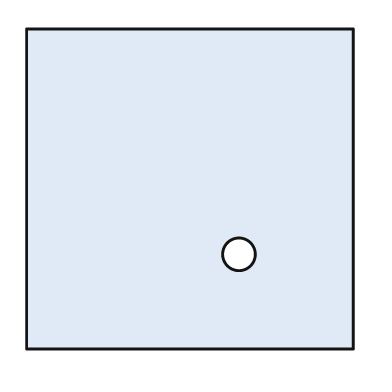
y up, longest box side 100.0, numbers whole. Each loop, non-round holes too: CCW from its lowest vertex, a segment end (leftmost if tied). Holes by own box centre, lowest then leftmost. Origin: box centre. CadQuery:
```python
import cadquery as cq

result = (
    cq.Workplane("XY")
    .moveTo(-50.0, -49.0)
    .lineTo(50.0, -49.0)
    .lineTo(50.0, 49.0)
    .lineTo(-50.0, 49.0)
    .close()
    .moveTo(15.0, -20.0)
    .circle(5.0)
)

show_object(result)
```